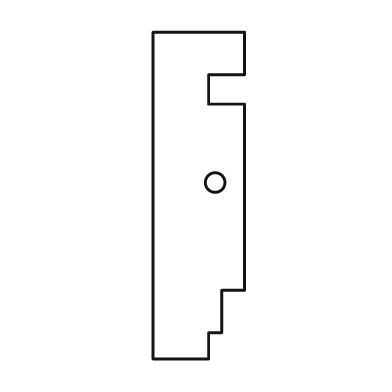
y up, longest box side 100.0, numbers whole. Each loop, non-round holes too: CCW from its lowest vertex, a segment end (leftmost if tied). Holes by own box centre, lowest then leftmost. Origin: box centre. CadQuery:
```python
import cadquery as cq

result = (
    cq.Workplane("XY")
    .moveTo(-14.0, -50.0)
    .lineTo(3.0, -50.0)
    .lineTo(3.0, -42.0)
    .lineTo(7.0, -42.0)
    .lineTo(7.0, -29.0)
    .lineTo(14.0, -29.0)
    .lineTo(14.0, 28.0)
    .lineTo(3.0, 28.0)
    .lineTo(3.0, 37.0)
    .lineTo(14.0, 37.0)
    .lineTo(14.0, 50.0)
    .lineTo(-14.0, 50.0)
    .close()
    .moveTo(5.0, 4.0)
    .circle(3.0)
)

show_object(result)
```